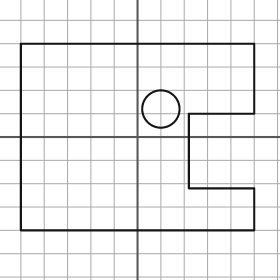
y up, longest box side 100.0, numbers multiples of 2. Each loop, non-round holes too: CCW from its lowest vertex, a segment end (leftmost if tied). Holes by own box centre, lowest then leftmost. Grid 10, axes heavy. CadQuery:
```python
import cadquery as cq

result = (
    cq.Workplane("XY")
    .moveTo(-50.0, -40.0)
    .lineTo(50.0, -40.0)
    .lineTo(50.0, -22.0)
    .lineTo(22.0, -22.0)
    .lineTo(22.0, 10.0)
    .lineTo(50.0, 10.0)
    .lineTo(50.0, 40.0)
    .lineTo(-50.0, 40.0)
    .close()
    .moveTo(10.0, 12.0)
    .circle(8.0)
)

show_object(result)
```